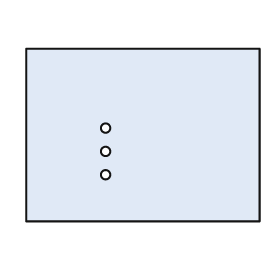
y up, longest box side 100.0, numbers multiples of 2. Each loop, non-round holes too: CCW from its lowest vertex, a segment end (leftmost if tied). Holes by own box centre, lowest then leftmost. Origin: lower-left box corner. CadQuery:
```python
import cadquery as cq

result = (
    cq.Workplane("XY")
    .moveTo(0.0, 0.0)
    .lineTo(100.0, 0.0)
    .lineTo(100.0, 74.0)
    .lineTo(0.0, 74.0)
    .close()
    .moveTo(34.0, 20.0)
    .circle(2.0)
    .moveTo(34.0, 30.0)
    .circle(2.0)
    .moveTo(34.0, 40.0)
    .circle(2.0)
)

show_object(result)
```